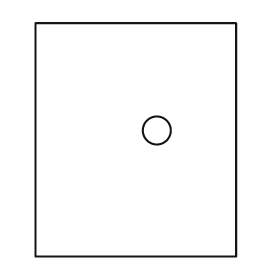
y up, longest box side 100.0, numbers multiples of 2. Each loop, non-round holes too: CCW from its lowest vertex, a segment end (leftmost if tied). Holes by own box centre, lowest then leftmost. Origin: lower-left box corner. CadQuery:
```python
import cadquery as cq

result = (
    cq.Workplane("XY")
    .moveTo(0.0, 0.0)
    .lineTo(86.0, 0.0)
    .lineTo(86.0, 100.0)
    .lineTo(0.0, 100.0)
    .close()
    .moveTo(52.0, 54.0)
    .circle(6.0)
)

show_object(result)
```